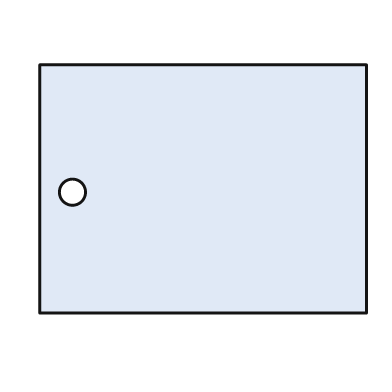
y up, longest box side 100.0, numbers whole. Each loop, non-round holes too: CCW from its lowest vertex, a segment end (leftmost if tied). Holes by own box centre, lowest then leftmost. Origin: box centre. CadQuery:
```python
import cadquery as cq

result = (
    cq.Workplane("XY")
    .moveTo(-50.0, -38.0)
    .lineTo(50.0, -38.0)
    .lineTo(50.0, 38.0)
    .lineTo(-50.0, 38.0)
    .close()
    .moveTo(-40.0, -1.0)
    .circle(4.0)
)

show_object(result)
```